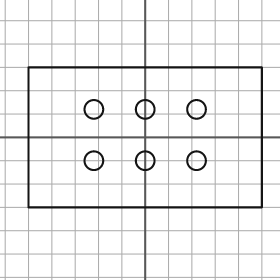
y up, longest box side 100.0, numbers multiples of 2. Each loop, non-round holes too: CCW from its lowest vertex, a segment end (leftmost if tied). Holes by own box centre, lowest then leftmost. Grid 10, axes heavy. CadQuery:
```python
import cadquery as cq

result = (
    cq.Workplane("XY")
    .moveTo(-50.0, -30.0)
    .lineTo(50.0, -30.0)
    .lineTo(50.0, 30.0)
    .lineTo(-50.0, 30.0)
    .close()
    .moveTo(-22.0, -10.0)
    .circle(4.0)
    .moveTo(0.0, -10.0)
    .circle(4.0)
    .moveTo(22.0, -10.0)
    .circle(4.0)
    .moveTo(-22.0, 12.0)
    .circle(4.0)
    .moveTo(0.0, 12.0)
    .circle(4.0)
    .moveTo(22.0, 12.0)
    .circle(4.0)
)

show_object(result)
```